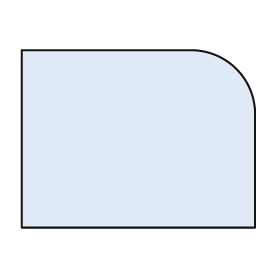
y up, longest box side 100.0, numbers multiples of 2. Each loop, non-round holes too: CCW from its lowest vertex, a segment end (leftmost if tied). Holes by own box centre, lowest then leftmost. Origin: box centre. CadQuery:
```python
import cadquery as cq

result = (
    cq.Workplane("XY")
    .moveTo(-50.0, -38.0)
    .lineTo(50.0, -38.0)
    .lineTo(50.0, 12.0)
    .threePointArc((42.0, 30.0), (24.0, 38.0))
    .lineTo(-50.0, 38.0)
    .close()
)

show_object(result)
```